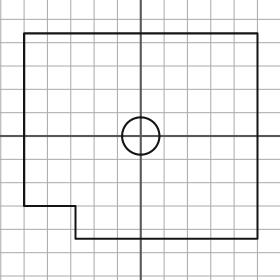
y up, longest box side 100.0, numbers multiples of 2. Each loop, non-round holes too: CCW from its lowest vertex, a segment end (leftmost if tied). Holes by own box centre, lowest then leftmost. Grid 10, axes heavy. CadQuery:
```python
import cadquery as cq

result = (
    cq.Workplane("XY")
    .moveTo(-28.0, -44.0)
    .lineTo(50.0, -44.0)
    .lineTo(50.0, 44.0)
    .lineTo(-50.0, 44.0)
    .lineTo(-50.0, -30.0)
    .lineTo(-28.0, -30.0)
    .close()
    .moveTo(0.0, 0.0)
    .circle(8.0)
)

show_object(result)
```